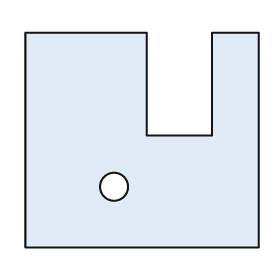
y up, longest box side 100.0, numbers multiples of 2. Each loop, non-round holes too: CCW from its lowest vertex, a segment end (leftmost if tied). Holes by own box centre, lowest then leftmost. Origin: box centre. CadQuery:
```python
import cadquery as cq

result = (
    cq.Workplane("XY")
    .moveTo(-50.0, -46.0)
    .lineTo(50.0, -46.0)
    .lineTo(50.0, 46.0)
    .lineTo(30.0, 46.0)
    .lineTo(30.0, 2.0)
    .lineTo(2.0, 2.0)
    .lineTo(2.0, 46.0)
    .lineTo(-50.0, 46.0)
    .close()
    .moveTo(-12.0, -20.0)
    .circle(6.0)
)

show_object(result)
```